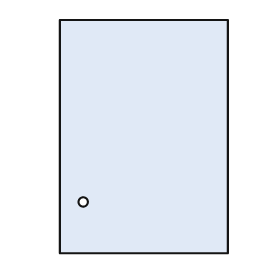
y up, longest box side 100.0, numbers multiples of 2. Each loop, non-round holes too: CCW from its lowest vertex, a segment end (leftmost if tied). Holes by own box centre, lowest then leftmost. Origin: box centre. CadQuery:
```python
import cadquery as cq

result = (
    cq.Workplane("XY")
    .moveTo(-36.0, -50.0)
    .lineTo(36.0, -50.0)
    .lineTo(36.0, 50.0)
    .lineTo(-36.0, 50.0)
    .close()
    .moveTo(-26.0, -28.0)
    .circle(2.0)
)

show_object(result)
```